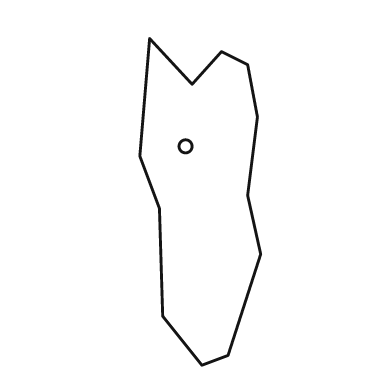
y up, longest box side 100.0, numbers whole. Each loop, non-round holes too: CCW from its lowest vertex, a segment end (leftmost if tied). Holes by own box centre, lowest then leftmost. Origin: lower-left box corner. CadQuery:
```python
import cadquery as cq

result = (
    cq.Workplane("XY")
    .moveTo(19.0, 0.0)
    .lineTo(27.0, 3.0)
    .lineTo(37.0, 34.0)
    .lineTo(33.0, 52.0)
    .lineTo(36.0, 76.0)
    .lineTo(33.0, 92.0)
    .lineTo(25.0, 96.0)
    .lineTo(16.0, 86.0)
    .lineTo(3.0, 100.0)
    .lineTo(0.0, 64.0)
    .lineTo(6.0, 48.0)
    .lineTo(7.0, 15.0)
    .close()
    .moveTo(14.0, 67.0)
    .circle(2.0)
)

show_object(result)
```